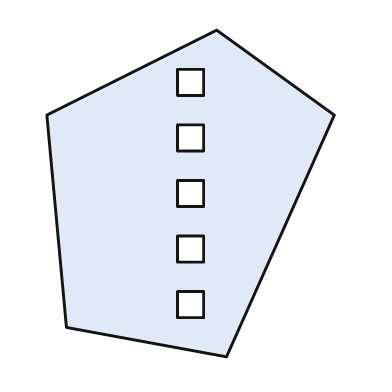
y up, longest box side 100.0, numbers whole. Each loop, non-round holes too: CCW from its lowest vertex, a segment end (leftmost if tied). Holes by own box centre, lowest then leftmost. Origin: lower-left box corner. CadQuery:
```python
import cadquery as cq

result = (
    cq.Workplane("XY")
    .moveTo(55.0, 0.0)
    .lineTo(88.0, 74.0)
    .lineTo(52.0, 100.0)
    .lineTo(0.0, 74.0)
    .lineTo(6.0, 9.0)
    .close()
    .moveTo(40.0, 12.0)
    .lineTo(48.0, 12.0)
    .lineTo(48.0, 20.0)
    .lineTo(40.0, 20.0)
    .close()
    .moveTo(40.0, 29.0)
    .lineTo(48.0, 29.0)
    .lineTo(48.0, 37.0)
    .lineTo(40.0, 37.0)
    .close()
    .moveTo(40.0, 46.0)
    .lineTo(48.0, 46.0)
    .lineTo(48.0, 54.0)
    .lineTo(40.0, 54.0)
    .close()
    .moveTo(40.0, 63.0)
    .lineTo(48.0, 63.0)
    .lineTo(48.0, 71.0)
    .lineTo(40.0, 71.0)
    .close()
    .moveTo(40.0, 80.0)
    .lineTo(48.0, 80.0)
    .lineTo(48.0, 88.0)
    .lineTo(40.0, 88.0)
    .close()
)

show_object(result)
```